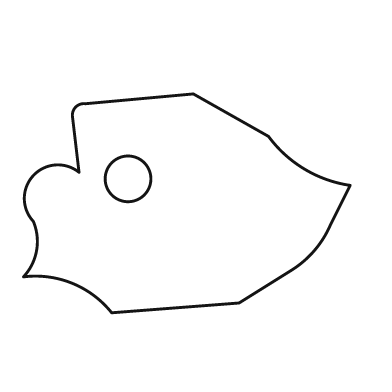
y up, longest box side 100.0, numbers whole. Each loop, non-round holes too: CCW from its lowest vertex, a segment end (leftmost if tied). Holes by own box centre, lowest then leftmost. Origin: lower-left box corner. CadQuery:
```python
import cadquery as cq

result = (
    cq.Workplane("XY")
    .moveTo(27.0, 0.0)
    .lineTo(66.0, 3.0)
    .lineTo(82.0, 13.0)
    .threePointArc((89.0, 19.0), (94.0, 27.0))
    .lineTo(100.0, 39.0)
    .threePointArc((86.0, 44.0), (75.0, 54.0))
    .lineTo(52.0, 67.0)
    .lineTo(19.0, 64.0)
    .threePointArc((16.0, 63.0), (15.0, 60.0))
    .lineTo(17.0, 43.0)
    .threePointArc((3.0, 42.0), (3.0, 28.0))
    .threePointArc((4.0, 19.0), (0.0, 11.0))
    .threePointArc((15.0, 9.0), (27.0, 0.0))
    .close()
    .moveTo(32.0, 41.0)
    .circle(7.0)
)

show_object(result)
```